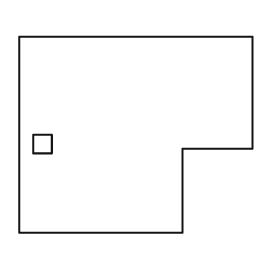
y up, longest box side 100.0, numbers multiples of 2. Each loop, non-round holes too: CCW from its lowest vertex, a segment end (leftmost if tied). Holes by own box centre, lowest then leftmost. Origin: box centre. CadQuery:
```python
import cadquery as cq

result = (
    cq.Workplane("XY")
    .moveTo(-50.0, -42.0)
    .lineTo(20.0, -42.0)
    .lineTo(20.0, -6.0)
    .lineTo(50.0, -6.0)
    .lineTo(50.0, 42.0)
    .lineTo(-50.0, 42.0)
    .close()
    .moveTo(-44.0, -8.0)
    .lineTo(-36.0, -8.0)
    .lineTo(-36.0, 0.0)
    .lineTo(-44.0, 0.0)
    .close()
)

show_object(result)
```